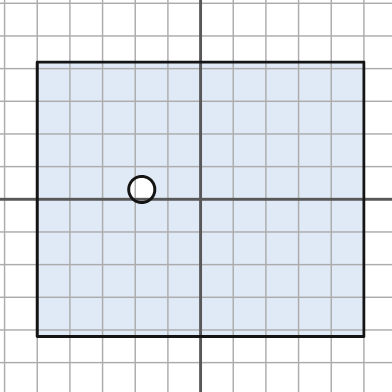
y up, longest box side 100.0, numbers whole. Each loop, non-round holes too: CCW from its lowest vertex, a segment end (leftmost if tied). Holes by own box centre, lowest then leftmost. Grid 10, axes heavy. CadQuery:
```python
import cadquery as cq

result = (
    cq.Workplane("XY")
    .moveTo(-50.0, -42.0)
    .lineTo(50.0, -42.0)
    .lineTo(50.0, 42.0)
    .lineTo(-50.0, 42.0)
    .close()
    .moveTo(-18.0, 3.0)
    .circle(4.0)
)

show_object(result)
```